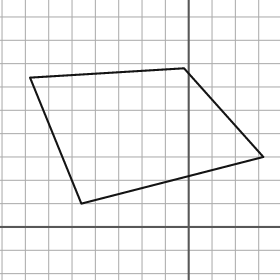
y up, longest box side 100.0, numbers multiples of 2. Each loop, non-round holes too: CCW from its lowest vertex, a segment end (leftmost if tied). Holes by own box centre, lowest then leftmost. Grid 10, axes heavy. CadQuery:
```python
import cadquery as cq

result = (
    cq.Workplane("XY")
    .moveTo(-46.0, 10.0)
    .lineTo(32.0, 30.0)
    .lineTo(-2.0, 68.0)
    .lineTo(-68.0, 64.0)
    .close()
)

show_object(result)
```